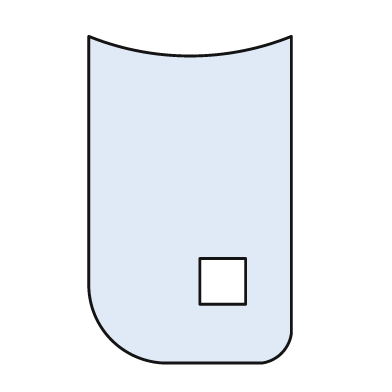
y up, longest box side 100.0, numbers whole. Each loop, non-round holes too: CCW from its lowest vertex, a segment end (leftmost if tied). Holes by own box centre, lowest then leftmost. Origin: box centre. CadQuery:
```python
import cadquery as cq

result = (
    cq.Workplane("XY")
    .moveTo(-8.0, -50.0)
    .lineTo(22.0, -50.0)
    .threePointArc((28.0, -47.0), (31.0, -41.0))
    .lineTo(31.0, 50.0)
    .threePointArc((0.0, 44.0), (-31.0, 50.0))
    .lineTo(-31.0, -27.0)
    .threePointArc((-24.0, -43.0), (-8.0, -50.0))
    .close()
    .moveTo(3.0, -32.0)
    .lineTo(17.0, -32.0)
    .lineTo(17.0, -18.0)
    .lineTo(3.0, -18.0)
    .close()
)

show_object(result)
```